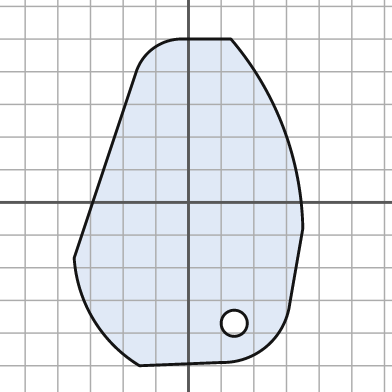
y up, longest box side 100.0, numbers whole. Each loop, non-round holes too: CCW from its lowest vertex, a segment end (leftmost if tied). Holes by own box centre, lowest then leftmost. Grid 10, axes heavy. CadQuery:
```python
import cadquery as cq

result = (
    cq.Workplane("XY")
    .moveTo(-15.0, -50.0)
    .lineTo(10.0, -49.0)
    .threePointArc((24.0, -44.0), (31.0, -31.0))
    .lineTo(35.0, -8.0)
    .threePointArc((29.0, 23.0), (13.0, 50.0))
    .lineTo(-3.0, 50.0)
    .threePointArc((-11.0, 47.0), (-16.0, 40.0))
    .lineTo(-35.0, -17.0)
    .threePointArc((-29.0, -36.0), (-15.0, -50.0))
    .close()
    .moveTo(14.0, -37.0)
    .circle(4.0)
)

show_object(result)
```